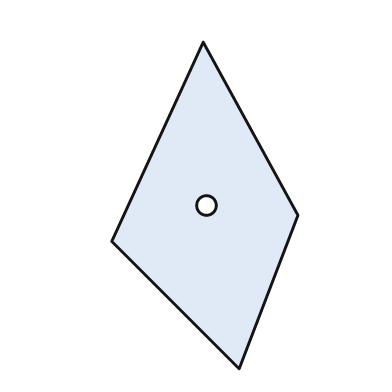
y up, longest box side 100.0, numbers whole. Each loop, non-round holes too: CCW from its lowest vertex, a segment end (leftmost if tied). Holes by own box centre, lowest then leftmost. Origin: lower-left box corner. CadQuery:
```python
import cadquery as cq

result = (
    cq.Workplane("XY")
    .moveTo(39.0, 0.0)
    .lineTo(57.0, 47.0)
    .lineTo(28.0, 100.0)
    .lineTo(0.0, 39.0)
    .close()
    .moveTo(29.0, 50.0)
    .circle(3.0)
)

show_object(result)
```